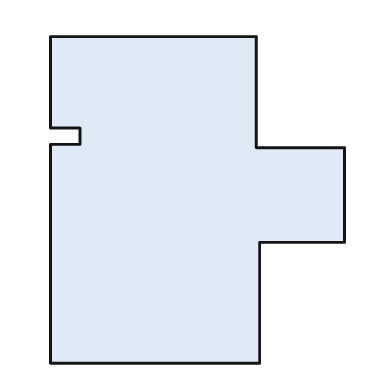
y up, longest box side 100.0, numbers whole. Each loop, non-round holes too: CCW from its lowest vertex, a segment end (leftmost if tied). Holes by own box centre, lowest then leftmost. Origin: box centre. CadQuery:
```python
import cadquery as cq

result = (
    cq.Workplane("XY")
    .moveTo(-45.0, -50.0)
    .lineTo(19.0, -50.0)
    .lineTo(19.0, -13.0)
    .lineTo(45.0, -13.0)
    .lineTo(45.0, 16.0)
    .lineTo(18.0, 16.0)
    .lineTo(18.0, 50.0)
    .lineTo(-45.0, 50.0)
    .lineTo(-45.0, 22.0)
    .lineTo(-36.0, 22.0)
    .lineTo(-36.0, 17.0)
    .lineTo(-45.0, 17.0)
    .close()
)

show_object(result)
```